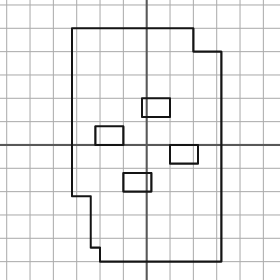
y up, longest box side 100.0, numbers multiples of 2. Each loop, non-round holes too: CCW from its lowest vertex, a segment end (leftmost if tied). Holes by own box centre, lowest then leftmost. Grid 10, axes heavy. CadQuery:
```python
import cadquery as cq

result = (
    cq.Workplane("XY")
    .moveTo(-20.0, -50.0)
    .lineTo(32.0, -50.0)
    .lineTo(32.0, 40.0)
    .lineTo(20.0, 40.0)
    .lineTo(20.0, 50.0)
    .lineTo(-32.0, 50.0)
    .lineTo(-32.0, -22.0)
    .lineTo(-24.0, -22.0)
    .lineTo(-24.0, -44.0)
    .lineTo(-20.0, -44.0)
    .close()
    .moveTo(-10.0, -20.0)
    .lineTo(2.0, -20.0)
    .lineTo(2.0, -12.0)
    .lineTo(-10.0, -12.0)
    .close()
    .moveTo(10.0, -8.0)
    .lineTo(22.0, -8.0)
    .lineTo(22.0, 0.0)
    .lineTo(10.0, 0.0)
    .close()
    .moveTo(-22.0, 0.0)
    .lineTo(-10.0, 0.0)
    .lineTo(-10.0, 8.0)
    .lineTo(-22.0, 8.0)
    .close()
    .moveTo(-2.0, 12.0)
    .lineTo(10.0, 12.0)
    .lineTo(10.0, 20.0)
    .lineTo(-2.0, 20.0)
    .close()
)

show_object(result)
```